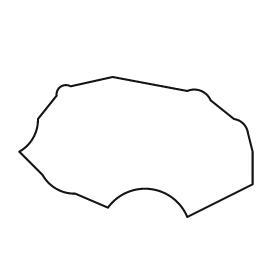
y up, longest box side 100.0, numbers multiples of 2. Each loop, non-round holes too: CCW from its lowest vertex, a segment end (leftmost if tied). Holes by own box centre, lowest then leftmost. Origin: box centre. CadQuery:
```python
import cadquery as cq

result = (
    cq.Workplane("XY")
    .moveTo(22.0, -30.0)
    .lineTo(50.0, -16.0)
    .lineTo(50.0, -2.0)
    .lineTo(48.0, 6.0)
    .threePointArc((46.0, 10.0), (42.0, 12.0))
    .lineTo(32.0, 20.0)
    .threePointArc((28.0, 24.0), (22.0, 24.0))
    .lineTo(-10.0, 30.0)
    .lineTo(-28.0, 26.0)
    .threePointArc((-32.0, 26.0), (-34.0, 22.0))
    .lineTo(-42.0, 12.0)
    .threePointArc((-44.0, 4.0), (-50.0, -2.0))
    .lineTo(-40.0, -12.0)
    .threePointArc((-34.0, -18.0), (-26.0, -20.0))
    .lineTo(-12.0, -26.0)
    .threePointArc((6.0, -18.0), (22.0, -30.0))
    .close()
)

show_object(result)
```